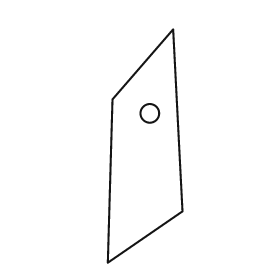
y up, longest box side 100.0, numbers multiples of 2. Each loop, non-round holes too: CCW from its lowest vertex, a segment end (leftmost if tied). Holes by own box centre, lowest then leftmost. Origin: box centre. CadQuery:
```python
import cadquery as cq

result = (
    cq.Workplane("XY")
    .moveTo(-16.0, -50.0)
    .lineTo(16.0, -28.0)
    .lineTo(12.0, 50.0)
    .lineTo(-14.0, 20.0)
    .close()
    .moveTo(2.0, 14.0)
    .circle(4.0)
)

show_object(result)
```